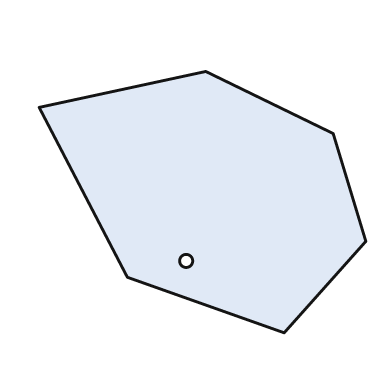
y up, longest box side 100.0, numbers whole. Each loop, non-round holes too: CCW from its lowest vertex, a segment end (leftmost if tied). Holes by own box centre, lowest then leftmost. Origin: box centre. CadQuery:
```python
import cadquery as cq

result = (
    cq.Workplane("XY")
    .moveTo(25.0, -40.0)
    .lineTo(50.0, -12.0)
    .lineTo(40.0, 21.0)
    .lineTo(1.0, 40.0)
    .lineTo(-50.0, 29.0)
    .lineTo(-23.0, -23.0)
    .close()
    .moveTo(-5.0, -18.0)
    .circle(2.0)
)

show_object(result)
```